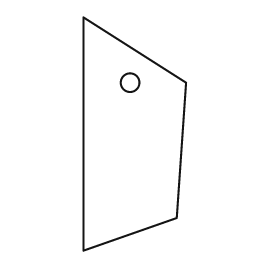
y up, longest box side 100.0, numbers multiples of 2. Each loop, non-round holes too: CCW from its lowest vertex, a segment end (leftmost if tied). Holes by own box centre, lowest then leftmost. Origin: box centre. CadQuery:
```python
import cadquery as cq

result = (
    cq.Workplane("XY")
    .moveTo(-22.0, -50.0)
    .lineTo(18.0, -36.0)
    .lineTo(22.0, 22.0)
    .lineTo(-22.0, 50.0)
    .close()
    .moveTo(-2.0, 22.0)
    .circle(4.0)
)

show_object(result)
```